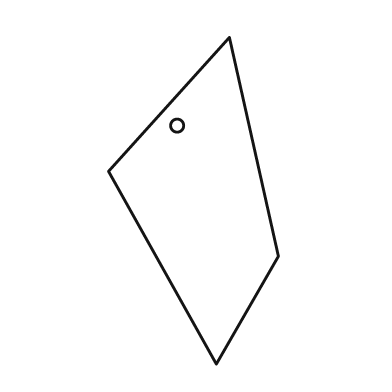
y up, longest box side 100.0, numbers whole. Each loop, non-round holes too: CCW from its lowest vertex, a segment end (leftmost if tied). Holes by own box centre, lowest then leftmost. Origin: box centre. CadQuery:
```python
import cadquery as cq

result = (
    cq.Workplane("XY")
    .moveTo(7.0, -50.0)
    .lineTo(26.0, -17.0)
    .lineTo(11.0, 50.0)
    .lineTo(-26.0, 9.0)
    .close()
    .moveTo(-5.0, 23.0)
    .circle(2.0)
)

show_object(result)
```